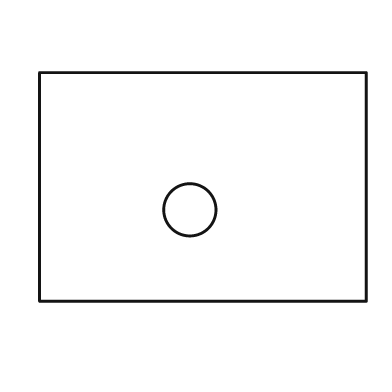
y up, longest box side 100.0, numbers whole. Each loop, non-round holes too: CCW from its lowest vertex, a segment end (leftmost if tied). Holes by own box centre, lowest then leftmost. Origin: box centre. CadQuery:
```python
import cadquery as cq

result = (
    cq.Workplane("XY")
    .moveTo(-50.0, -35.0)
    .lineTo(50.0, -35.0)
    .lineTo(50.0, 35.0)
    .lineTo(-50.0, 35.0)
    .close()
    .moveTo(-4.0, -7.0)
    .circle(8.0)
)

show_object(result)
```